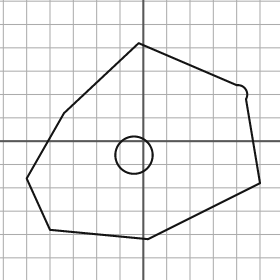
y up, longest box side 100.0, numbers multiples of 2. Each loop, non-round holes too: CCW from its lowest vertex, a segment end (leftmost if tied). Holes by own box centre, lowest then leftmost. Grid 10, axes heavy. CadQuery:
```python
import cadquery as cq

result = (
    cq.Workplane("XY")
    .moveTo(2.0, -42.0)
    .lineTo(50.0, -18.0)
    .lineTo(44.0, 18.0)
    .threePointArc((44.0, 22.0), (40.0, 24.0))
    .lineTo(-2.0, 42.0)
    .lineTo(-34.0, 12.0)
    .lineTo(-50.0, -16.0)
    .lineTo(-40.0, -38.0)
    .close()
    .moveTo(-4.0, -6.0)
    .circle(8.0)
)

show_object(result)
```